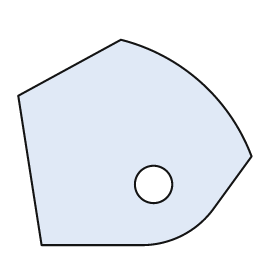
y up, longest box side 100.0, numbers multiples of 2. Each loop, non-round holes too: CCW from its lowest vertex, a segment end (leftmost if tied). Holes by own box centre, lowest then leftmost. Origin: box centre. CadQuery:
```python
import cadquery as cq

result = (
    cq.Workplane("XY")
    .moveTo(-40.0, -44.0)
    .lineTo(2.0, -44.0)
    .threePointArc((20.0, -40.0), (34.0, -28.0))
    .lineTo(50.0, -6.0)
    .threePointArc((28.0, 26.0), (-6.0, 44.0))
    .lineTo(-50.0, 20.0)
    .close()
    .moveTo(8.0, -18.0)
    .circle(8.0)
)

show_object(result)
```